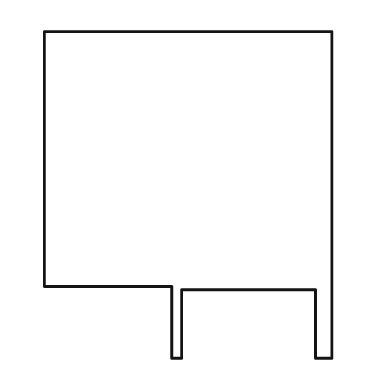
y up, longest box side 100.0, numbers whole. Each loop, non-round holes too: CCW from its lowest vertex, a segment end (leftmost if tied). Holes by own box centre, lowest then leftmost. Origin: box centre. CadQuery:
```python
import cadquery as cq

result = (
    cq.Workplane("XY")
    .moveTo(-5.0, -50.0)
    .lineTo(-2.0, -50.0)
    .lineTo(-2.0, -29.0)
    .lineTo(39.0, -29.0)
    .lineTo(39.0, -50.0)
    .lineTo(44.0, -50.0)
    .lineTo(44.0, 50.0)
    .lineTo(-44.0, 50.0)
    .lineTo(-44.0, -28.0)
    .lineTo(-5.0, -28.0)
    .close()
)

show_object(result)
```